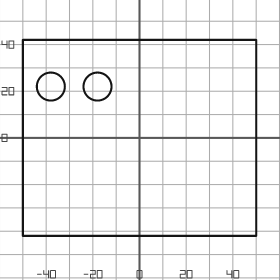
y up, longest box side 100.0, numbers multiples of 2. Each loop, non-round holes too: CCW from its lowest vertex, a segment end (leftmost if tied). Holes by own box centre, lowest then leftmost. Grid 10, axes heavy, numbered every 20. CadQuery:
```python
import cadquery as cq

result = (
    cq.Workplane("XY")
    .moveTo(-50.0, -42.0)
    .lineTo(50.0, -42.0)
    .lineTo(50.0, 42.0)
    .lineTo(-50.0, 42.0)
    .close()
    .moveTo(-38.0, 22.0)
    .circle(6.0)
    .moveTo(-18.0, 22.0)
    .circle(6.0)
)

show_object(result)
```